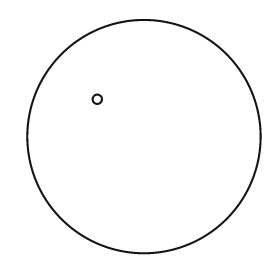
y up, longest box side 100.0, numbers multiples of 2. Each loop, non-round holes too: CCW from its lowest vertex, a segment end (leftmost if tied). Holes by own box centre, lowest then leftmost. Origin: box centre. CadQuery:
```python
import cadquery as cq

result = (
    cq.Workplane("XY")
    .moveTo(0.0, 0.0)
    .circle(50.0)
    .moveTo(-20.0, 16.0)
    .circle(2.0)
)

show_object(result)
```